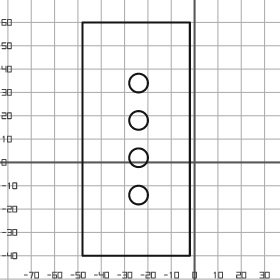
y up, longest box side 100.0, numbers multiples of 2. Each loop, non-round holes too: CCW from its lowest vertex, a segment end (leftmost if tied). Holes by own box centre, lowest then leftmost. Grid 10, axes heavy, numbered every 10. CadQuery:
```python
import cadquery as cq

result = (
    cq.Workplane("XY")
    .moveTo(-48.0, -40.0)
    .lineTo(-2.0, -40.0)
    .lineTo(-2.0, 60.0)
    .lineTo(-48.0, 60.0)
    .close()
    .moveTo(-24.0, -14.0)
    .circle(4.0)
    .moveTo(-24.0, 2.0)
    .circle(4.0)
    .moveTo(-24.0, 18.0)
    .circle(4.0)
    .moveTo(-24.0, 34.0)
    .circle(4.0)
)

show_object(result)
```